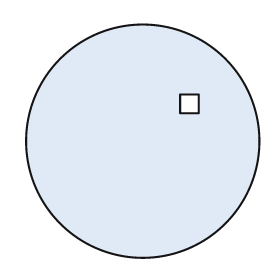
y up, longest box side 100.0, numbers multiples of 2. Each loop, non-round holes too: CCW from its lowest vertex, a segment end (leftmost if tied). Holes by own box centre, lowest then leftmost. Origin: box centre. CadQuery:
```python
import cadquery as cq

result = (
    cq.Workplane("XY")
    .moveTo(0.0, 0.0)
    .circle(50.0)
    .moveTo(16.0, 12.0)
    .lineTo(24.0, 12.0)
    .lineTo(24.0, 20.0)
    .lineTo(16.0, 20.0)
    .close()
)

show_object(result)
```